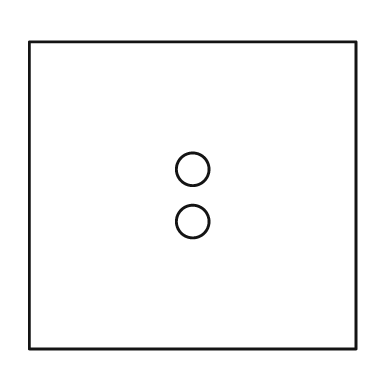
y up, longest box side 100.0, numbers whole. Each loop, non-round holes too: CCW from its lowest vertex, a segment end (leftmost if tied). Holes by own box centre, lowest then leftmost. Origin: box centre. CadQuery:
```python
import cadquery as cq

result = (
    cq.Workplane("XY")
    .moveTo(-50.0, -47.0)
    .lineTo(50.0, -47.0)
    .lineTo(50.0, 47.0)
    .lineTo(-50.0, 47.0)
    .close()
    .moveTo(0.0, -8.0)
    .circle(5.0)
    .moveTo(0.0, 8.0)
    .circle(5.0)
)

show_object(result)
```